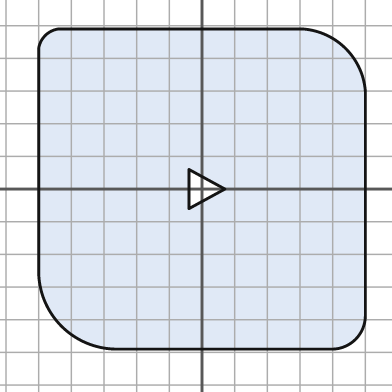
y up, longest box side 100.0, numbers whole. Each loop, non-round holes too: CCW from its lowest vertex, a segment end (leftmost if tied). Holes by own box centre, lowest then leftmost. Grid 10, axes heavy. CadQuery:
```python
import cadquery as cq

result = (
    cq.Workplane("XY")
    .moveTo(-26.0, -49.0)
    .lineTo(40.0, -49.0)
    .threePointArc((47.0, -46.0), (50.0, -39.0))
    .lineTo(50.0, 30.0)
    .threePointArc((44.0, 43.0), (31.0, 49.0))
    .lineTo(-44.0, 49.0)
    .threePointArc((-48.0, 47.0), (-50.0, 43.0))
    .lineTo(-50.0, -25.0)
    .threePointArc((-43.0, -42.0), (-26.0, -49.0))
    .close()
    .moveTo(-4.0, -6.0)
    .lineTo(7.0, 0.0)
    .lineTo(-4.0, 6.0)
    .close()
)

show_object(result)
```